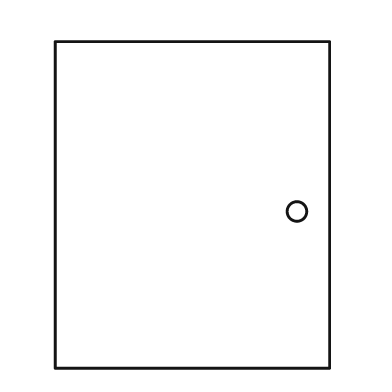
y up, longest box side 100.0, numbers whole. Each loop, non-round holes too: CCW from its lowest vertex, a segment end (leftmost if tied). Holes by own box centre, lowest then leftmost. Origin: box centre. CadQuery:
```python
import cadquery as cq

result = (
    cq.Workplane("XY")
    .moveTo(-42.0, -50.0)
    .lineTo(42.0, -50.0)
    .lineTo(42.0, 50.0)
    .lineTo(-42.0, 50.0)
    .close()
    .moveTo(32.0, -2.0)
    .circle(3.0)
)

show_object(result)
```